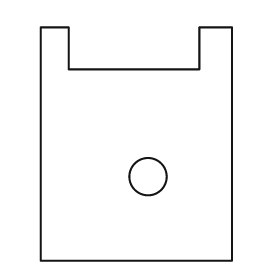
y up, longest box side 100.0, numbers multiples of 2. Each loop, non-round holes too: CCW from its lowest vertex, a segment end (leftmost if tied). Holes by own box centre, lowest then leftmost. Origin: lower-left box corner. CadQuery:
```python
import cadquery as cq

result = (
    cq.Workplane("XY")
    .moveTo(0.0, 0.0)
    .lineTo(82.0, 0.0)
    .lineTo(82.0, 100.0)
    .lineTo(68.0, 100.0)
    .lineTo(68.0, 82.0)
    .lineTo(12.0, 82.0)
    .lineTo(12.0, 100.0)
    .lineTo(0.0, 100.0)
    .close()
    .moveTo(46.0, 36.0)
    .circle(8.0)
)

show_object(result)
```